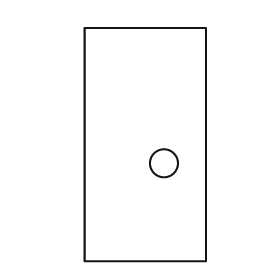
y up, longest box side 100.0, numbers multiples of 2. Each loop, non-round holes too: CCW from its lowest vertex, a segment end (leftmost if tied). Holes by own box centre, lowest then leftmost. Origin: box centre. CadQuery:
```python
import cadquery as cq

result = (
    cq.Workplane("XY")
    .moveTo(-26.0, -50.0)
    .lineTo(26.0, -50.0)
    .lineTo(26.0, 50.0)
    .lineTo(-26.0, 50.0)
    .close()
    .moveTo(8.0, -8.0)
    .circle(6.0)
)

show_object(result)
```